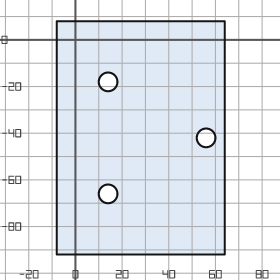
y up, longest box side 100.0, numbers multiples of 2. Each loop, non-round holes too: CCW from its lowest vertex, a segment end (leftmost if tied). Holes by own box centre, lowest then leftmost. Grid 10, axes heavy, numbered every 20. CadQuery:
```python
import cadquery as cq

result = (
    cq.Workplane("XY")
    .moveTo(-8.0, -92.0)
    .lineTo(64.0, -92.0)
    .lineTo(64.0, 8.0)
    .lineTo(-8.0, 8.0)
    .close()
    .moveTo(14.0, -66.0)
    .circle(4.0)
    .moveTo(56.0, -42.0)
    .circle(4.0)
    .moveTo(14.0, -18.0)
    .circle(4.0)
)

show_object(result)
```